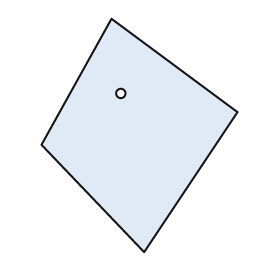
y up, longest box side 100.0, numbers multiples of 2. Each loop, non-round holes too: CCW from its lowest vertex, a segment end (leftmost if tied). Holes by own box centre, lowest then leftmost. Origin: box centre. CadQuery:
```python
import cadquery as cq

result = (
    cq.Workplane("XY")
    .moveTo(2.0, -50.0)
    .lineTo(42.0, 10.0)
    .lineTo(-12.0, 50.0)
    .lineTo(-42.0, -4.0)
    .close()
    .moveTo(-8.0, 18.0)
    .circle(2.0)
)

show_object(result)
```